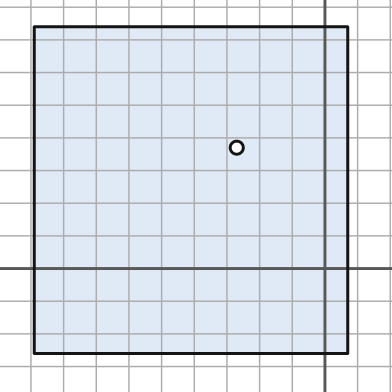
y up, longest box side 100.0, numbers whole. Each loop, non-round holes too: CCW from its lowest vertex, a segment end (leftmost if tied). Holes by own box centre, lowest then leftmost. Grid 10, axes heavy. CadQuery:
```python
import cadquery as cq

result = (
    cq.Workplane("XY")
    .moveTo(-89.0, -26.0)
    .lineTo(7.0, -26.0)
    .lineTo(7.0, 74.0)
    .lineTo(-89.0, 74.0)
    .close()
    .moveTo(-27.0, 37.0)
    .circle(2.0)
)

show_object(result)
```